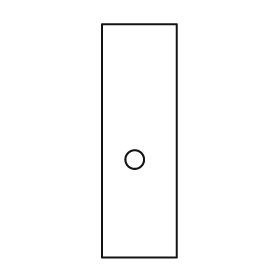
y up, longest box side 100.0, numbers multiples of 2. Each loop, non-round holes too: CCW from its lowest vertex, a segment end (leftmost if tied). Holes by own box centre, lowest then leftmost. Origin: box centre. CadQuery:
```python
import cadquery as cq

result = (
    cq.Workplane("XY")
    .moveTo(-16.0, -50.0)
    .lineTo(16.0, -50.0)
    .lineTo(16.0, 50.0)
    .lineTo(-16.0, 50.0)
    .close()
    .moveTo(-2.0, -8.0)
    .circle(4.0)
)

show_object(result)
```